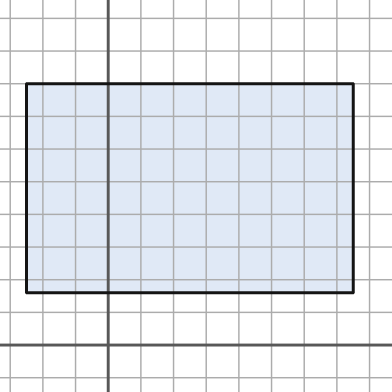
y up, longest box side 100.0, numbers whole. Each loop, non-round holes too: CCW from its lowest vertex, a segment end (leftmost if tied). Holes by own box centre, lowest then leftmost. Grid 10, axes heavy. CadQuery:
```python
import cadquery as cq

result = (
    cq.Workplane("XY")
    .moveTo(-25.0, 16.0)
    .lineTo(75.0, 16.0)
    .lineTo(75.0, 80.0)
    .lineTo(-25.0, 80.0)
    .close()
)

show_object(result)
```